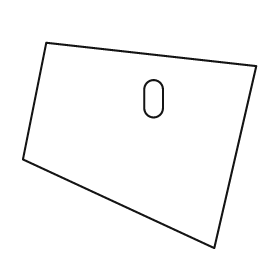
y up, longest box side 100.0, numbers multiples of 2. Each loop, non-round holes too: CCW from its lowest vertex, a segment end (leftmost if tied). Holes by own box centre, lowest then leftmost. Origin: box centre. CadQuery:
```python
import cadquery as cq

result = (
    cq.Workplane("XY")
    .moveTo(32.0, -44.0)
    .lineTo(50.0, 34.0)
    .lineTo(-40.0, 44.0)
    .lineTo(-50.0, -6.0)
    .close()
    .moveTo(2.0, 16.0)
    .threePointArc((6.0, 12.0), (10.0, 16.0))
    .lineTo(10.0, 24.0)
    .threePointArc((6.0, 28.0), (2.0, 24.0))
    .close()
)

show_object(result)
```